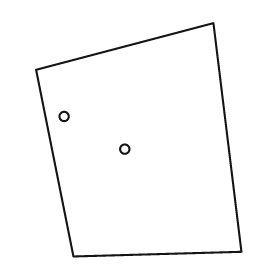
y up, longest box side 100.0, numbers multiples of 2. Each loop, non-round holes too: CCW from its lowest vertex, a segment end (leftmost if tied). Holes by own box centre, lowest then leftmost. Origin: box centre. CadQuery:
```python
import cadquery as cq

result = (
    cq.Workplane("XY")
    .moveTo(-28.0, -50.0)
    .lineTo(44.0, -48.0)
    .lineTo(32.0, 50.0)
    .lineTo(-44.0, 30.0)
    .close()
    .moveTo(-6.0, -4.0)
    .circle(2.0)
    .moveTo(-32.0, 10.0)
    .circle(2.0)
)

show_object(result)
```